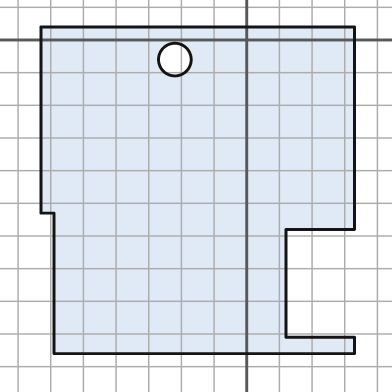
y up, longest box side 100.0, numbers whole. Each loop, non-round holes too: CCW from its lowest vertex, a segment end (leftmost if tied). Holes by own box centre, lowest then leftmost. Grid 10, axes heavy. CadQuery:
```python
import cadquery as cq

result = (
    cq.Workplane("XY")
    .moveTo(-59.0, -96.0)
    .lineTo(33.0, -96.0)
    .lineTo(33.0, -91.0)
    .lineTo(12.0, -91.0)
    .lineTo(12.0, -58.0)
    .lineTo(33.0, -58.0)
    .lineTo(33.0, 4.0)
    .lineTo(-63.0, 4.0)
    .lineTo(-63.0, -53.0)
    .lineTo(-59.0, -53.0)
    .close()
    .moveTo(-22.0, -6.0)
    .circle(5.0)
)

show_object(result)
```